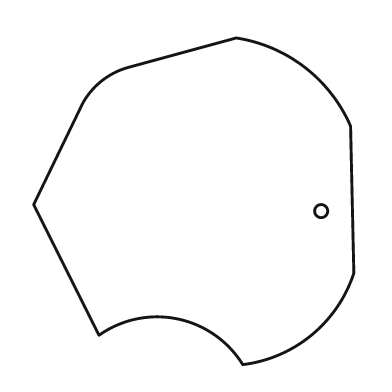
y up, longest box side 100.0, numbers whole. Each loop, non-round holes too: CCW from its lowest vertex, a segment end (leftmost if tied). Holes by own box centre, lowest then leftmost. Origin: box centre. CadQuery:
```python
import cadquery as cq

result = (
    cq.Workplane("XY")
    .moveTo(15.0, -50.0)
    .threePointArc((36.0, -41.0), (49.0, -22.0))
    .lineTo(48.0, 23.0)
    .threePointArc((34.0, 41.0), (13.0, 50.0))
    .lineTo(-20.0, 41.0)
    .threePointArc((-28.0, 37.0), (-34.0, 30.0))
    .lineTo(-49.0, -1.0)
    .lineTo(-29.0, -41.0)
    .threePointArc((-5.0, -36.0), (15.0, -50.0))
    .close()
    .moveTo(39.0, -3.0)
    .circle(2.0)
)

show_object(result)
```